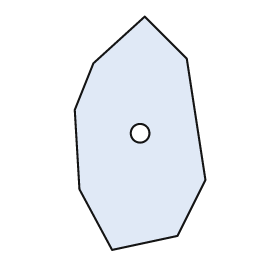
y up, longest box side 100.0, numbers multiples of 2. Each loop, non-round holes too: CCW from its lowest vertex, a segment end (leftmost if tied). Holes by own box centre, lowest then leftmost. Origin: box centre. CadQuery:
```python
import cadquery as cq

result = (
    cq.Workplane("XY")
    .moveTo(-12.0, -50.0)
    .lineTo(16.0, -44.0)
    .lineTo(28.0, -20.0)
    .lineTo(20.0, 32.0)
    .lineTo(2.0, 50.0)
    .lineTo(-20.0, 30.0)
    .lineTo(-28.0, 10.0)
    .lineTo(-26.0, -24.0)
    .close()
    .moveTo(0.0, 0.0)
    .circle(4.0)
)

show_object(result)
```